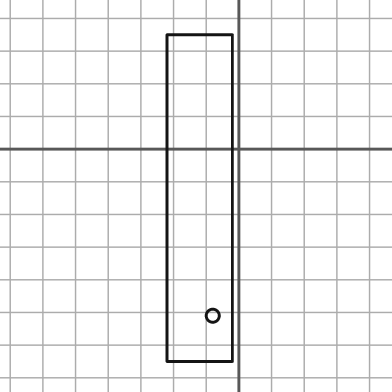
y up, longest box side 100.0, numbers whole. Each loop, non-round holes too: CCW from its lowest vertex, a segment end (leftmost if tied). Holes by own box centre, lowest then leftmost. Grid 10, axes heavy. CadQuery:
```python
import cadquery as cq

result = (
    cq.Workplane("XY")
    .moveTo(-22.0, -65.0)
    .lineTo(-2.0, -65.0)
    .lineTo(-2.0, 35.0)
    .lineTo(-22.0, 35.0)
    .close()
    .moveTo(-8.0, -51.0)
    .circle(2.0)
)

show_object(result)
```